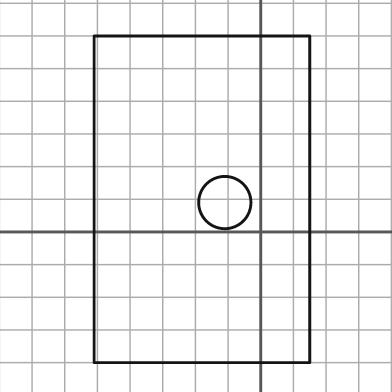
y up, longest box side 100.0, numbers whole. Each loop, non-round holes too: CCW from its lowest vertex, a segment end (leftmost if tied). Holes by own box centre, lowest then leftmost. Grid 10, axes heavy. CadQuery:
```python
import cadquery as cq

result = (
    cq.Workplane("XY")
    .moveTo(-51.0, -40.0)
    .lineTo(15.0, -40.0)
    .lineTo(15.0, 60.0)
    .lineTo(-51.0, 60.0)
    .close()
    .moveTo(-11.0, 9.0)
    .circle(8.0)
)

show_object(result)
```